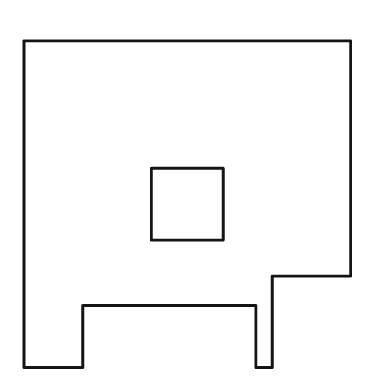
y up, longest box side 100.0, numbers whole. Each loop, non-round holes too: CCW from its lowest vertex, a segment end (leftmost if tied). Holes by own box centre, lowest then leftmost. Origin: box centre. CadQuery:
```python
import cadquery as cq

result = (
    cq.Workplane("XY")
    .moveTo(-50.0, -50.0)
    .lineTo(-32.0, -50.0)
    .lineTo(-32.0, -31.0)
    .lineTo(21.0, -31.0)
    .lineTo(21.0, -50.0)
    .lineTo(26.0, -50.0)
    .lineTo(26.0, -22.0)
    .lineTo(50.0, -22.0)
    .lineTo(50.0, 50.0)
    .lineTo(-50.0, 50.0)
    .close()
    .moveTo(-11.0, -11.0)
    .lineTo(11.0, -11.0)
    .lineTo(11.0, 11.0)
    .lineTo(-11.0, 11.0)
    .close()
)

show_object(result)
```